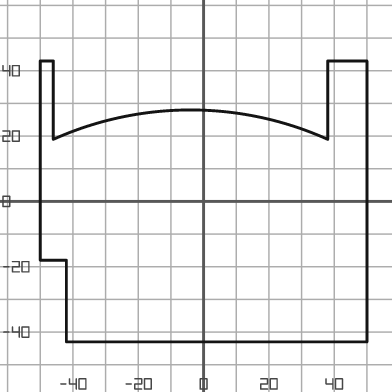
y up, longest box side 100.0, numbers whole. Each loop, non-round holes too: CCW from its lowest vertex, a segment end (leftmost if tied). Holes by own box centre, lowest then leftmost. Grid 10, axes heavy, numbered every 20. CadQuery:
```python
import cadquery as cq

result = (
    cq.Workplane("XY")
    .moveTo(-42.0, -43.0)
    .lineTo(50.0, -43.0)
    .lineTo(50.0, 43.0)
    .lineTo(38.0, 43.0)
    .lineTo(38.0, 19.0)
    .threePointArc((-4.0, 28.0), (-46.0, 19.0))
    .lineTo(-46.0, 43.0)
    .lineTo(-50.0, 43.0)
    .lineTo(-50.0, -18.0)
    .lineTo(-42.0, -18.0)
    .close()
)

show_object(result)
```